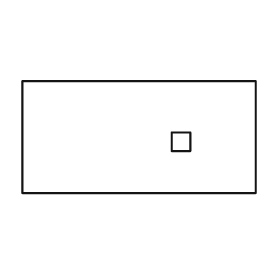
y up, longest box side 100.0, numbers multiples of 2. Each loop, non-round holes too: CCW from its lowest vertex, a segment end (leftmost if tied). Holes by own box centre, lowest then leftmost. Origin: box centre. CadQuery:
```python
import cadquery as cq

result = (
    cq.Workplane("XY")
    .moveTo(-50.0, -24.0)
    .lineTo(50.0, -24.0)
    .lineTo(50.0, 24.0)
    .lineTo(-50.0, 24.0)
    .close()
    .moveTo(14.0, -6.0)
    .lineTo(22.0, -6.0)
    .lineTo(22.0, 2.0)
    .lineTo(14.0, 2.0)
    .close()
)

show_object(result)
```